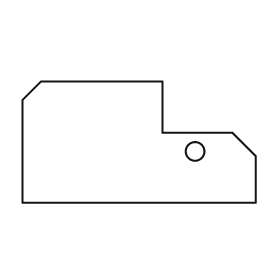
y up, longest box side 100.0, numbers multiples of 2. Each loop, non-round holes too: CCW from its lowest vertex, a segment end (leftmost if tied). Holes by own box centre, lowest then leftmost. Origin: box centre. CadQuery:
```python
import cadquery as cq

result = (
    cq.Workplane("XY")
    .moveTo(-50.0, -26.0)
    .lineTo(50.0, -26.0)
    .lineTo(50.0, -6.0)
    .lineTo(40.0, 4.0)
    .lineTo(10.0, 4.0)
    .lineTo(10.0, 26.0)
    .lineTo(-42.0, 26.0)
    .lineTo(-50.0, 18.0)
    .close()
    .moveTo(24.0, -4.0)
    .circle(4.0)
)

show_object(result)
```